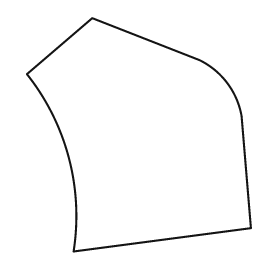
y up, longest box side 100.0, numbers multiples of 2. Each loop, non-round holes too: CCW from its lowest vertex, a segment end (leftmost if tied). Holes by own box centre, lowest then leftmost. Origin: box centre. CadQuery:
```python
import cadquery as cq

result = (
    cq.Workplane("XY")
    .moveTo(-28.0, -50.0)
    .lineTo(48.0, -40.0)
    .lineTo(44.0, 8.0)
    .threePointArc((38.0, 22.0), (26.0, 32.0))
    .lineTo(-20.0, 50.0)
    .lineTo(-48.0, 26.0)
    .threePointArc((-30.0, -10.0), (-28.0, -50.0))
    .close()
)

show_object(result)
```